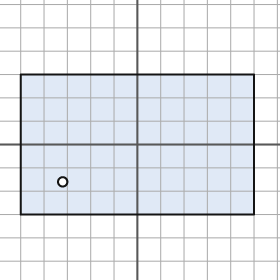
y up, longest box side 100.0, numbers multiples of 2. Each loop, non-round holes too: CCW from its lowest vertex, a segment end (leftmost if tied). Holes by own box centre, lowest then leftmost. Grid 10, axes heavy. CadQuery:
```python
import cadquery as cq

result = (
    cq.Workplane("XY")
    .moveTo(-50.0, -30.0)
    .lineTo(50.0, -30.0)
    .lineTo(50.0, 30.0)
    .lineTo(-50.0, 30.0)
    .close()
    .moveTo(-32.0, -16.0)
    .circle(2.0)
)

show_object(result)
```